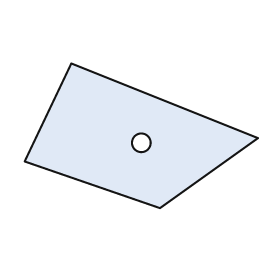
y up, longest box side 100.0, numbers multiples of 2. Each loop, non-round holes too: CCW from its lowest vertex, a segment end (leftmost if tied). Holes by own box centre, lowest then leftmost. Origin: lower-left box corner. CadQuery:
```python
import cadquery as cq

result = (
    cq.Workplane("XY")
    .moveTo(58.0, 0.0)
    .lineTo(100.0, 30.0)
    .lineTo(20.0, 62.0)
    .lineTo(0.0, 20.0)
    .close()
    .moveTo(50.0, 28.0)
    .circle(4.0)
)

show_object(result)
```